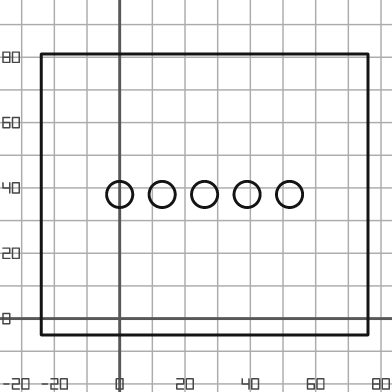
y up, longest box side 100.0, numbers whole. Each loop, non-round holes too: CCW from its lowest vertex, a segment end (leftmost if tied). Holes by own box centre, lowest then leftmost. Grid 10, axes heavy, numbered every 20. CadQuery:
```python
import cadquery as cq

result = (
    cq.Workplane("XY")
    .moveTo(-24.0, -5.0)
    .lineTo(76.0, -5.0)
    .lineTo(76.0, 81.0)
    .lineTo(-24.0, 81.0)
    .close()
    .moveTo(0.0, 38.0)
    .circle(4.0)
    .moveTo(13.0, 38.0)
    .circle(4.0)
    .moveTo(26.0, 38.0)
    .circle(4.0)
    .moveTo(39.0, 38.0)
    .circle(4.0)
    .moveTo(52.0, 38.0)
    .circle(4.0)
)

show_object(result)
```